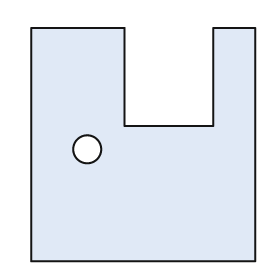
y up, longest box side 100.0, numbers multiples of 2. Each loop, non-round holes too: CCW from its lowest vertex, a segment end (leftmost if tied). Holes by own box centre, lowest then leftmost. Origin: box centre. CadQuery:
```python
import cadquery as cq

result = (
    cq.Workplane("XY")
    .moveTo(-48.0, -50.0)
    .lineTo(48.0, -50.0)
    .lineTo(48.0, 50.0)
    .lineTo(30.0, 50.0)
    .lineTo(30.0, 8.0)
    .lineTo(-8.0, 8.0)
    .lineTo(-8.0, 50.0)
    .lineTo(-48.0, 50.0)
    .close()
    .moveTo(-24.0, -2.0)
    .circle(6.0)
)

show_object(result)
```